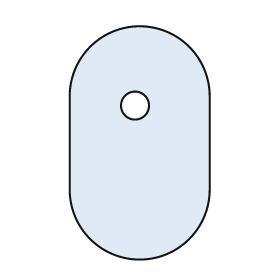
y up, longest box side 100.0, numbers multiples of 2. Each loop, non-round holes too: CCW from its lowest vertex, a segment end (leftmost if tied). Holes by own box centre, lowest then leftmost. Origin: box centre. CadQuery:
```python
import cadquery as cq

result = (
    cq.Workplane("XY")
    .moveTo(-30.0, -20.0)
    .threePointArc((0.0, -50.0), (30.0, -20.0))
    .lineTo(30.0, 20.0)
    .threePointArc((0.0, 50.0), (-30.0, 20.0))
    .close()
    .moveTo(-2.0, 16.0)
    .circle(6.0)
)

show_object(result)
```